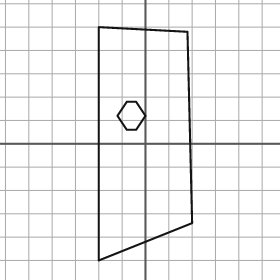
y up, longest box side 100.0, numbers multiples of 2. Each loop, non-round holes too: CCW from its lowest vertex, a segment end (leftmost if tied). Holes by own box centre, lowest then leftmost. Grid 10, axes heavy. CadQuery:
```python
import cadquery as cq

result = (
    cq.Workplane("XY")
    .moveTo(-20.0, -50.0)
    .lineTo(20.0, -34.0)
    .lineTo(18.0, 48.0)
    .lineTo(-20.0, 50.0)
    .close()
    .moveTo(-8.0, 6.0)
    .lineTo(-4.0, 6.0)
    .lineTo(0.0, 12.0)
    .lineTo(-4.0, 18.0)
    .lineTo(-8.0, 18.0)
    .lineTo(-12.0, 12.0)
    .close()
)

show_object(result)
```